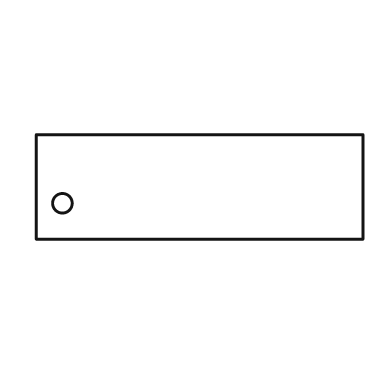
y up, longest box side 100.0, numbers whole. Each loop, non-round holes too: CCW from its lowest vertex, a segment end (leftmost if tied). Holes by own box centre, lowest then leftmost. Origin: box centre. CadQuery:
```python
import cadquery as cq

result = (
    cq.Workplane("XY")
    .moveTo(-50.0, -16.0)
    .lineTo(50.0, -16.0)
    .lineTo(50.0, 16.0)
    .lineTo(-50.0, 16.0)
    .close()
    .moveTo(-42.0, -5.0)
    .circle(3.0)
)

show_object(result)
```